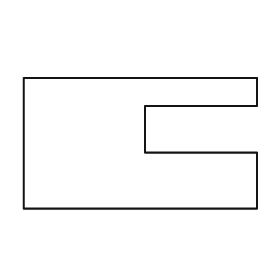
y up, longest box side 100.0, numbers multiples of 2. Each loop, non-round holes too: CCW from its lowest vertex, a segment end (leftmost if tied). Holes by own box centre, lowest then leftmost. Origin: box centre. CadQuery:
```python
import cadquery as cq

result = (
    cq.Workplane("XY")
    .moveTo(-50.0, -28.0)
    .lineTo(50.0, -28.0)
    .lineTo(50.0, -4.0)
    .lineTo(2.0, -4.0)
    .lineTo(2.0, 16.0)
    .lineTo(50.0, 16.0)
    .lineTo(50.0, 28.0)
    .lineTo(-50.0, 28.0)
    .close()
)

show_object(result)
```